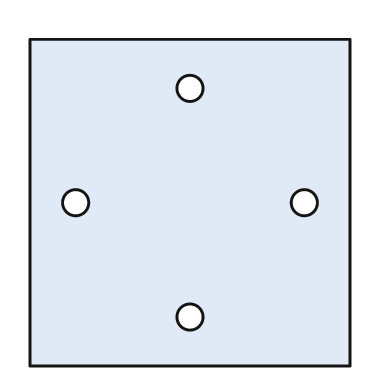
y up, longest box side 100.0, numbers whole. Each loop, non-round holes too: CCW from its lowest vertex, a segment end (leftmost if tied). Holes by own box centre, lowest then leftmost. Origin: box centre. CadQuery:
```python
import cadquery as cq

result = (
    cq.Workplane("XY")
    .moveTo(-49.0, -50.0)
    .lineTo(49.0, -50.0)
    .lineTo(49.0, 50.0)
    .lineTo(-49.0, 50.0)
    .close()
    .moveTo(0.0, -35.0)
    .circle(4.0)
    .moveTo(-35.0, 0.0)
    .circle(4.0)
    .moveTo(35.0, 0.0)
    .circle(4.0)
    .moveTo(0.0, 35.0)
    .circle(4.0)
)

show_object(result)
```